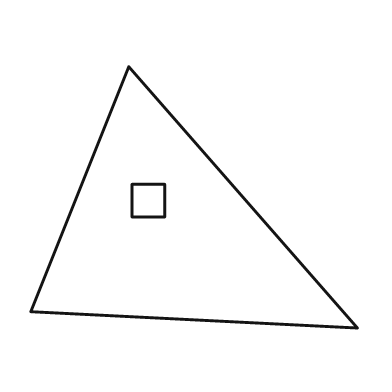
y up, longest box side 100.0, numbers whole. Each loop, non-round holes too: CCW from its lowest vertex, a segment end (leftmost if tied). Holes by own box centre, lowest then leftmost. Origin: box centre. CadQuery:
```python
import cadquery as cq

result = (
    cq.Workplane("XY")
    .moveTo(50.0, -40.0)
    .lineTo(-20.0, 40.0)
    .lineTo(-50.0, -35.0)
    .close()
    .moveTo(-19.0, -6.0)
    .lineTo(-9.0, -6.0)
    .lineTo(-9.0, 4.0)
    .lineTo(-19.0, 4.0)
    .close()
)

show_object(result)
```